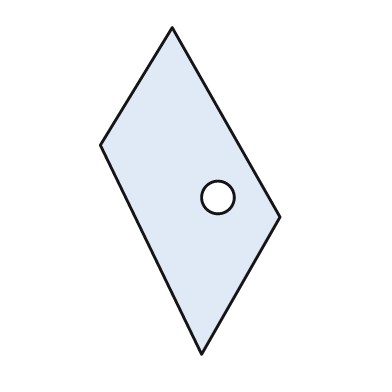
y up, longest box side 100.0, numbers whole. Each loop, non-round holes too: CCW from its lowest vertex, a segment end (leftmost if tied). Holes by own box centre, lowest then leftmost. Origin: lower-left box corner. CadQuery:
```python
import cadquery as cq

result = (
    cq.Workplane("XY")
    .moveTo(31.0, 0.0)
    .lineTo(55.0, 42.0)
    .lineTo(22.0, 100.0)
    .lineTo(0.0, 64.0)
    .close()
    .moveTo(36.0, 48.0)
    .circle(5.0)
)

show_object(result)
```